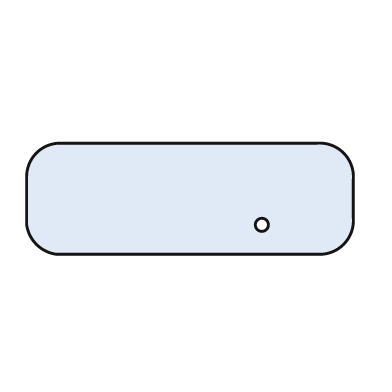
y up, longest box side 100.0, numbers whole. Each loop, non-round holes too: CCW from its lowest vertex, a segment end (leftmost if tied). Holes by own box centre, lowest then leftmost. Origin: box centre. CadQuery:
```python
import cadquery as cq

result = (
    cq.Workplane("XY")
    .moveTo(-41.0, -17.0)
    .lineTo(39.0, -17.0)
    .threePointArc((47.0, -14.0), (50.0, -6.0))
    .lineTo(50.0, 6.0)
    .threePointArc((47.0, 14.0), (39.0, 17.0))
    .lineTo(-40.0, 17.0)
    .threePointArc((-47.0, 14.0), (-50.0, 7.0))
    .lineTo(-50.0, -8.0)
    .threePointArc((-47.0, -14.0), (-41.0, -17.0))
    .close()
    .moveTo(22.0, -8.0)
    .circle(2.0)
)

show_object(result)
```